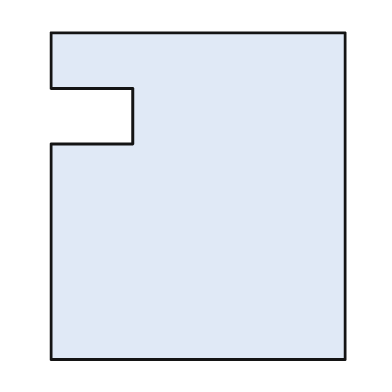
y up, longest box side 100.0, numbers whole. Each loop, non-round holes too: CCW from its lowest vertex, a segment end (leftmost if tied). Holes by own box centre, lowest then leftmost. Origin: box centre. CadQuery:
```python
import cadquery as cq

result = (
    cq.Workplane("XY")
    .moveTo(-45.0, -50.0)
    .lineTo(45.0, -50.0)
    .lineTo(45.0, 50.0)
    .lineTo(-45.0, 50.0)
    .lineTo(-45.0, 33.0)
    .lineTo(-20.0, 33.0)
    .lineTo(-20.0, 16.0)
    .lineTo(-45.0, 16.0)
    .close()
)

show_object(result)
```